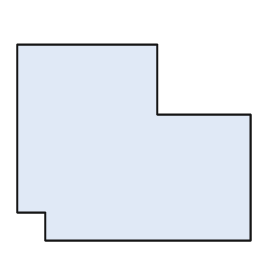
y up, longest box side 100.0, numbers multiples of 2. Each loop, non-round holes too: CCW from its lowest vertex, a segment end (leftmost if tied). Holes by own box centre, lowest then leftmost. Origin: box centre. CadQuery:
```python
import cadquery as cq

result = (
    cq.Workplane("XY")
    .moveTo(-38.0, -42.0)
    .lineTo(50.0, -42.0)
    .lineTo(50.0, 12.0)
    .lineTo(10.0, 12.0)
    .lineTo(10.0, 42.0)
    .lineTo(-50.0, 42.0)
    .lineTo(-50.0, -30.0)
    .lineTo(-38.0, -30.0)
    .close()
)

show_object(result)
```